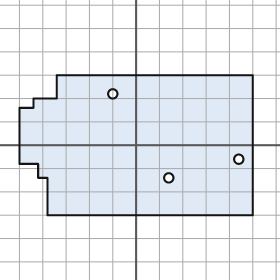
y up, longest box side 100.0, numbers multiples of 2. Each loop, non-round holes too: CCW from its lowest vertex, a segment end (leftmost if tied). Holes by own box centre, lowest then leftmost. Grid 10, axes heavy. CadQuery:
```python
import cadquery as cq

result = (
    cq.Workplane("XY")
    .moveTo(-38.0, -30.0)
    .lineTo(50.0, -30.0)
    .lineTo(50.0, 30.0)
    .lineTo(-34.0, 30.0)
    .lineTo(-34.0, 20.0)
    .lineTo(-44.0, 20.0)
    .lineTo(-44.0, 16.0)
    .lineTo(-50.0, 16.0)
    .lineTo(-50.0, -8.0)
    .lineTo(-42.0, -8.0)
    .lineTo(-42.0, -14.0)
    .lineTo(-38.0, -14.0)
    .close()
    .moveTo(14.0, -14.0)
    .circle(2.0)
    .moveTo(44.0, -6.0)
    .circle(2.0)
    .moveTo(-10.0, 22.0)
    .circle(2.0)
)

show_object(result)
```